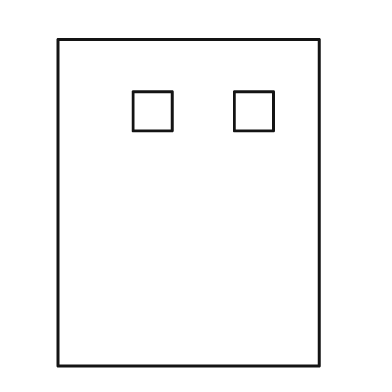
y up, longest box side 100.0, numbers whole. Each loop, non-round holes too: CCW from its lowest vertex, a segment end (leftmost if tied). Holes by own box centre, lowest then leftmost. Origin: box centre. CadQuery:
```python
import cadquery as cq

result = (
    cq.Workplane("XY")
    .moveTo(-40.0, -50.0)
    .lineTo(40.0, -50.0)
    .lineTo(40.0, 50.0)
    .lineTo(-40.0, 50.0)
    .close()
    .moveTo(-17.0, 22.0)
    .lineTo(-5.0, 22.0)
    .lineTo(-5.0, 34.0)
    .lineTo(-17.0, 34.0)
    .close()
    .moveTo(14.0, 22.0)
    .lineTo(26.0, 22.0)
    .lineTo(26.0, 34.0)
    .lineTo(14.0, 34.0)
    .close()
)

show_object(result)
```